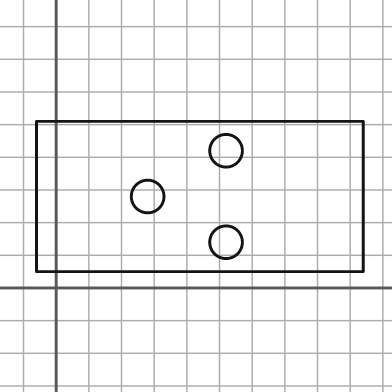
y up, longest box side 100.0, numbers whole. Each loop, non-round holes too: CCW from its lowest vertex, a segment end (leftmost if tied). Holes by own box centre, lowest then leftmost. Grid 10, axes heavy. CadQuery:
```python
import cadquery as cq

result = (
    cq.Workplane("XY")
    .moveTo(-6.0, 5.0)
    .lineTo(94.0, 5.0)
    .lineTo(94.0, 51.0)
    .lineTo(-6.0, 51.0)
    .close()
    .moveTo(52.0, 14.0)
    .circle(5.0)
    .moveTo(28.0, 28.0)
    .circle(5.0)
    .moveTo(52.0, 42.0)
    .circle(5.0)
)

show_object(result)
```